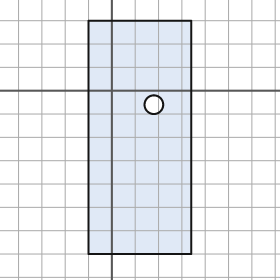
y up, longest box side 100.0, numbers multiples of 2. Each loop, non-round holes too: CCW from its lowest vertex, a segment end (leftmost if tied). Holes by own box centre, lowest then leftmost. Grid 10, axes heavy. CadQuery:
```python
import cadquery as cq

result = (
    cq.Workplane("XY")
    .moveTo(-10.0, -70.0)
    .lineTo(34.0, -70.0)
    .lineTo(34.0, 30.0)
    .lineTo(-10.0, 30.0)
    .close()
    .moveTo(18.0, -6.0)
    .circle(4.0)
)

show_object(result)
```